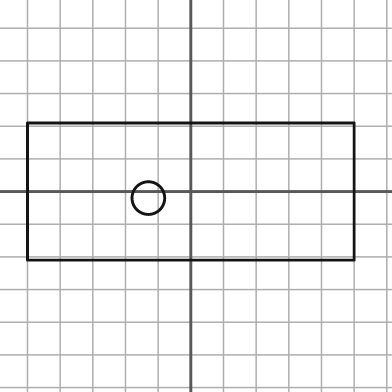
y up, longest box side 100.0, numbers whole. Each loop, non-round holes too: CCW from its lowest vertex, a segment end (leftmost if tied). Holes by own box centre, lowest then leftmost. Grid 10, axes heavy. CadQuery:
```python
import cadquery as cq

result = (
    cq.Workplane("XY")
    .moveTo(-50.0, -21.0)
    .lineTo(50.0, -21.0)
    .lineTo(50.0, 21.0)
    .lineTo(-50.0, 21.0)
    .close()
    .moveTo(-13.0, -2.0)
    .circle(5.0)
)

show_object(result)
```